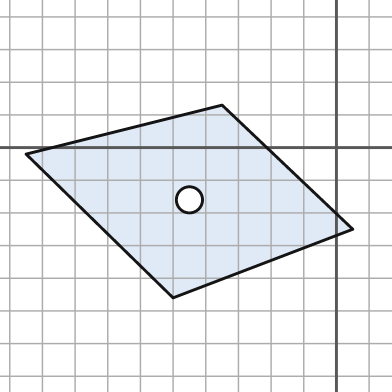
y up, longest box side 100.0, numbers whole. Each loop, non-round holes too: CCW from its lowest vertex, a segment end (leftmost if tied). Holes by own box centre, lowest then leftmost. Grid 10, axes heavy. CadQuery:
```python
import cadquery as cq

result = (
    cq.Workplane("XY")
    .moveTo(-50.0, -46.0)
    .lineTo(5.0, -25.0)
    .lineTo(-35.0, 13.0)
    .lineTo(-95.0, -2.0)
    .close()
    .moveTo(-45.0, -16.0)
    .circle(4.0)
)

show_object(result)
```